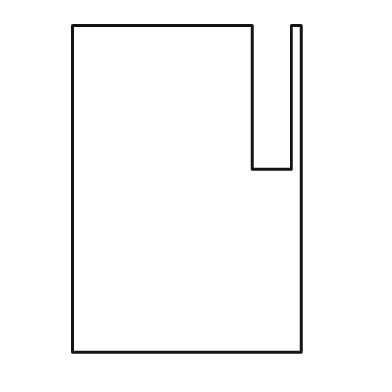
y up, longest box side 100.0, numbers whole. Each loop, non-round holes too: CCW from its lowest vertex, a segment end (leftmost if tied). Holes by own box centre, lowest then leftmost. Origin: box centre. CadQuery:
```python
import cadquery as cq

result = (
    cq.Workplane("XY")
    .moveTo(-35.0, -50.0)
    .lineTo(35.0, -50.0)
    .lineTo(35.0, 50.0)
    .lineTo(32.0, 50.0)
    .lineTo(32.0, 6.0)
    .lineTo(20.0, 6.0)
    .lineTo(20.0, 50.0)
    .lineTo(-35.0, 50.0)
    .close()
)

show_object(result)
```